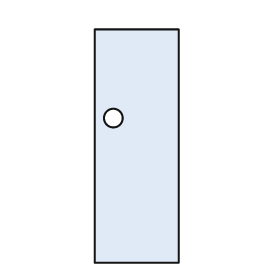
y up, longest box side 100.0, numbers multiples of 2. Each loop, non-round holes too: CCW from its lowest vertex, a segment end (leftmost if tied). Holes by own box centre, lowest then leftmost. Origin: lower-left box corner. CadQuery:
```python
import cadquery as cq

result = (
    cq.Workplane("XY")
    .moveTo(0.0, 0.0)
    .lineTo(36.0, 0.0)
    .lineTo(36.0, 100.0)
    .lineTo(0.0, 100.0)
    .close()
    .moveTo(8.0, 62.0)
    .circle(4.0)
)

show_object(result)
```